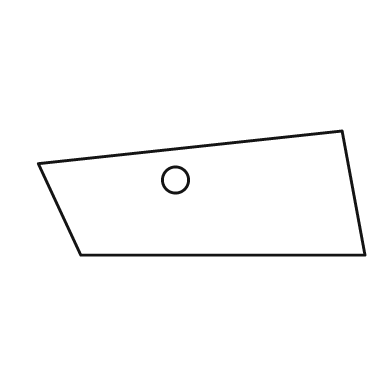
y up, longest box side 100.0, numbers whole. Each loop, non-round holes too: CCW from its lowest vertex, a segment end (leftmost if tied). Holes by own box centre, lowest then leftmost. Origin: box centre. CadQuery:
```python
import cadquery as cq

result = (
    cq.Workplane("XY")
    .moveTo(-37.0, -19.0)
    .lineTo(50.0, -19.0)
    .lineTo(43.0, 19.0)
    .lineTo(-50.0, 9.0)
    .close()
    .moveTo(-8.0, 4.0)
    .circle(4.0)
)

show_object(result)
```